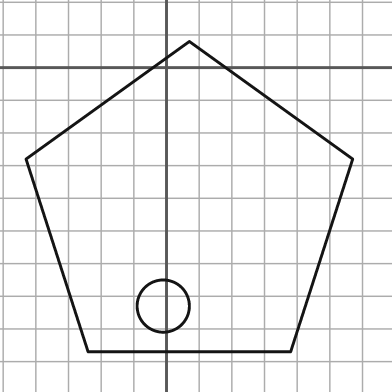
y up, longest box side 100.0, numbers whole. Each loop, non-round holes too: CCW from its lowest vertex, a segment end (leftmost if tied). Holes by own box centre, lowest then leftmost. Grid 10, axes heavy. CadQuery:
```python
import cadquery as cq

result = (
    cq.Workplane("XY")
    .moveTo(-24.0, -87.0)
    .lineTo(38.0, -87.0)
    .lineTo(57.0, -28.0)
    .lineTo(7.0, 8.0)
    .lineTo(-43.0, -28.0)
    .close()
    .moveTo(-1.0, -73.0)
    .circle(8.0)
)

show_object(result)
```